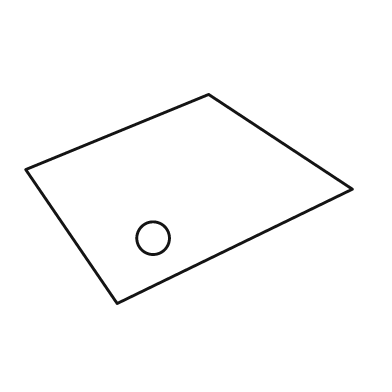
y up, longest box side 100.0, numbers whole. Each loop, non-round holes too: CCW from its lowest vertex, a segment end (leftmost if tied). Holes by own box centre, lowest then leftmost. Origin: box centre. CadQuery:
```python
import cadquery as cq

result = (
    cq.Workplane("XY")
    .moveTo(-22.0, -32.0)
    .lineTo(50.0, 3.0)
    .lineTo(6.0, 32.0)
    .lineTo(-50.0, 9.0)
    .close()
    .moveTo(-11.0, -12.0)
    .circle(5.0)
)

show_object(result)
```